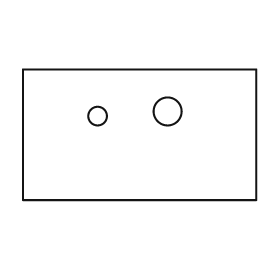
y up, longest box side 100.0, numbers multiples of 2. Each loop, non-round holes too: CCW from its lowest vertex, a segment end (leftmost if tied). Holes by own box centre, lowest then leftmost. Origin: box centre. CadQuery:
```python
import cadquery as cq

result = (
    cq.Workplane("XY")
    .moveTo(-50.0, -28.0)
    .lineTo(50.0, -28.0)
    .lineTo(50.0, 28.0)
    .lineTo(-50.0, 28.0)
    .close()
    .moveTo(-18.0, 8.0)
    .circle(4.0)
    .moveTo(12.0, 10.0)
    .circle(6.0)
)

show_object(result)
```